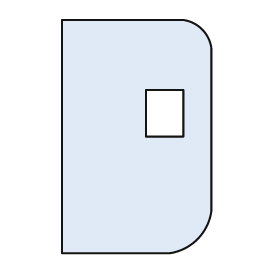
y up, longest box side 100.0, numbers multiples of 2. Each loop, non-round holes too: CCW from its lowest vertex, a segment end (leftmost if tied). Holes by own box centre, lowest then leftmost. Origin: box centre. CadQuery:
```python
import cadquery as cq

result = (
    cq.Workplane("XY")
    .moveTo(-32.0, -50.0)
    .lineTo(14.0, -50.0)
    .threePointArc((26.0, -44.0), (32.0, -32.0))
    .lineTo(32.0, 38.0)
    .threePointArc((28.0, 46.0), (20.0, 50.0))
    .lineTo(-32.0, 50.0)
    .close()
    .moveTo(4.0, 0.0)
    .lineTo(20.0, 0.0)
    .lineTo(20.0, 20.0)
    .lineTo(4.0, 20.0)
    .close()
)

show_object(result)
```